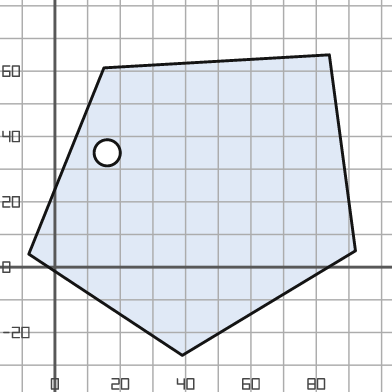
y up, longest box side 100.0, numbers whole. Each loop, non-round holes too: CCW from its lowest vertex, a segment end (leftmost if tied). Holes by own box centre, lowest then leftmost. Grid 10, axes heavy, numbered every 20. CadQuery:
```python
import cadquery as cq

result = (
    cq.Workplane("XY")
    .moveTo(39.0, -27.0)
    .lineTo(92.0, 5.0)
    .lineTo(84.0, 65.0)
    .lineTo(15.0, 61.0)
    .lineTo(-8.0, 4.0)
    .close()
    .moveTo(16.0, 35.0)
    .circle(4.0)
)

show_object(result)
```